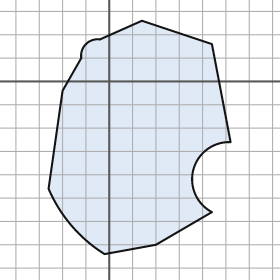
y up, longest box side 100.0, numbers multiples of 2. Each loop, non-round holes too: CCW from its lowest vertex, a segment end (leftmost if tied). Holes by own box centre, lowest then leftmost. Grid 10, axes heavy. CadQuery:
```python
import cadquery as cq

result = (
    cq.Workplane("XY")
    .moveTo(-2.0, -74.0)
    .lineTo(20.0, -70.0)
    .lineTo(44.0, -56.0)
    .threePointArc((36.0, -38.0), (52.0, -26.0))
    .lineTo(44.0, 16.0)
    .lineTo(14.0, 26.0)
    .lineTo(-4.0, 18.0)
    .threePointArc((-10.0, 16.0), (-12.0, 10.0))
    .lineTo(-20.0, -4.0)
    .lineTo(-26.0, -46.0)
    .threePointArc((-16.0, -62.0), (-2.0, -74.0))
    .close()
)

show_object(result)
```